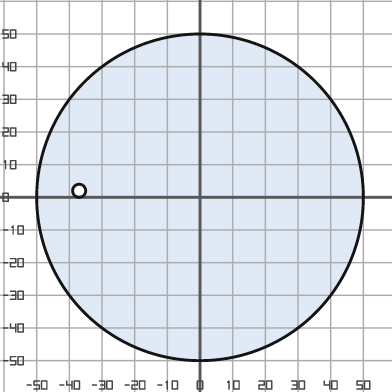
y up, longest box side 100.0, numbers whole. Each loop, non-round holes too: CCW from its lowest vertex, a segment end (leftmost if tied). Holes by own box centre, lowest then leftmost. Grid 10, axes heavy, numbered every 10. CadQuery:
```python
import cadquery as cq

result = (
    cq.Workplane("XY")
    .moveTo(0.0, 0.0)
    .circle(50.0)
    .moveTo(-37.0, 2.0)
    .circle(2.0)
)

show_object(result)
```